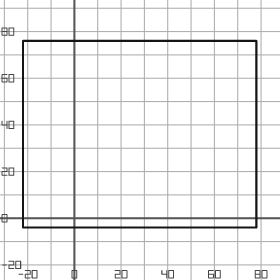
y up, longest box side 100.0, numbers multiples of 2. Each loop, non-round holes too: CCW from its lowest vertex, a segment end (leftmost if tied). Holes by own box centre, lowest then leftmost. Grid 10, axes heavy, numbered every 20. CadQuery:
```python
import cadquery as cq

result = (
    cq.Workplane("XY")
    .moveTo(-22.0, -4.0)
    .lineTo(78.0, -4.0)
    .lineTo(78.0, 76.0)
    .lineTo(-22.0, 76.0)
    .close()
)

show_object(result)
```